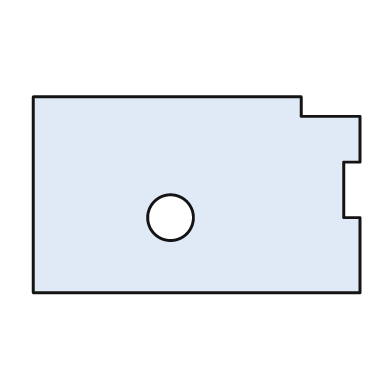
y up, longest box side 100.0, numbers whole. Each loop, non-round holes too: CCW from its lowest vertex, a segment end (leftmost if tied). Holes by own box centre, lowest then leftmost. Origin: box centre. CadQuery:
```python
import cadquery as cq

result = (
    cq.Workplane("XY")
    .moveTo(-50.0, -30.0)
    .lineTo(50.0, -30.0)
    .lineTo(50.0, -7.0)
    .lineTo(45.0, -7.0)
    .lineTo(45.0, 10.0)
    .lineTo(50.0, 10.0)
    .lineTo(50.0, 24.0)
    .lineTo(32.0, 24.0)
    .lineTo(32.0, 30.0)
    .lineTo(-50.0, 30.0)
    .close()
    .moveTo(-8.0, -7.0)
    .circle(7.0)
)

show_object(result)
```